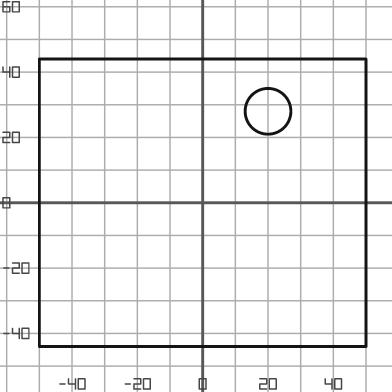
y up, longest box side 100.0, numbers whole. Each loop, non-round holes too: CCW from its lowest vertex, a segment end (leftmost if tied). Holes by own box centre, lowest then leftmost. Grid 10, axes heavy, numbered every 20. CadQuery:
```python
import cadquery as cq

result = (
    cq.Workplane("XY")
    .moveTo(-50.0, -44.0)
    .lineTo(50.0, -44.0)
    .lineTo(50.0, 44.0)
    .lineTo(-50.0, 44.0)
    .close()
    .moveTo(20.0, 28.0)
    .circle(7.0)
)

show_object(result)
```